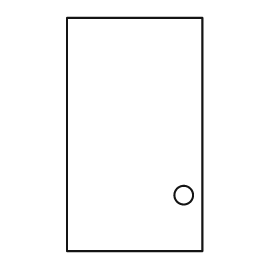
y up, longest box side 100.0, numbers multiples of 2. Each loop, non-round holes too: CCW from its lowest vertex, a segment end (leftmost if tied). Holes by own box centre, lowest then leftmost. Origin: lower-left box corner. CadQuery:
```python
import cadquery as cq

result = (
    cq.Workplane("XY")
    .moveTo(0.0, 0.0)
    .lineTo(58.0, 0.0)
    .lineTo(58.0, 100.0)
    .lineTo(0.0, 100.0)
    .close()
    .moveTo(50.0, 24.0)
    .circle(4.0)
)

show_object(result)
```